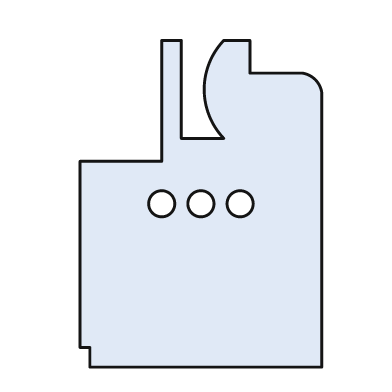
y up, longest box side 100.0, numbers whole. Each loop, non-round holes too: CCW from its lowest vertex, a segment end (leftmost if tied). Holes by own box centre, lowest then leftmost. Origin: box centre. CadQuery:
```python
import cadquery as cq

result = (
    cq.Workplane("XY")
    .moveTo(-34.0, -50.0)
    .lineTo(37.0, -50.0)
    .lineTo(37.0, 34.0)
    .threePointArc((35.0, 38.0), (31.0, 40.0))
    .lineTo(15.0, 40.0)
    .lineTo(15.0, 50.0)
    .lineTo(7.0, 50.0)
    .threePointArc((1.0, 35.0), (7.0, 20.0))
    .lineTo(-6.0, 20.0)
    .lineTo(-6.0, 50.0)
    .lineTo(-12.0, 50.0)
    .lineTo(-12.0, 13.0)
    .lineTo(-37.0, 13.0)
    .lineTo(-37.0, -44.0)
    .lineTo(-34.0, -44.0)
    .close()
    .moveTo(-12.0, 0.0)
    .circle(4.0)
    .moveTo(0.0, 0.0)
    .circle(4.0)
    .moveTo(12.0, 0.0)
    .circle(4.0)
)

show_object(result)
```